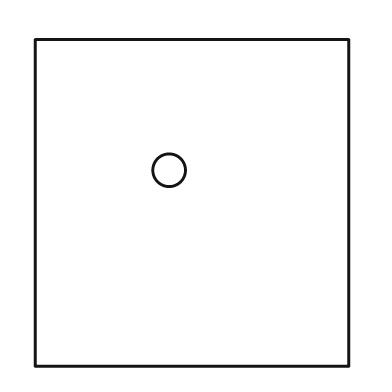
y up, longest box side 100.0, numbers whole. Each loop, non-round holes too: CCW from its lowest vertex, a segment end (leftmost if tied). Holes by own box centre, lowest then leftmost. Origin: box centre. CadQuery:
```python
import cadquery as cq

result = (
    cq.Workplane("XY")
    .moveTo(-48.0, -50.0)
    .lineTo(48.0, -50.0)
    .lineTo(48.0, 50.0)
    .lineTo(-48.0, 50.0)
    .close()
    .moveTo(-7.0, 10.0)
    .circle(5.0)
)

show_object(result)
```